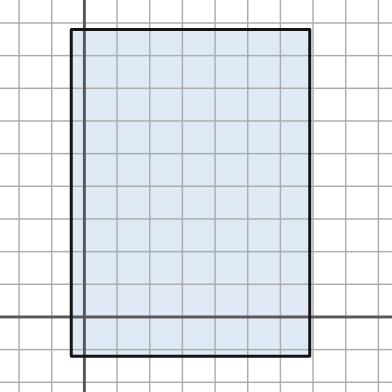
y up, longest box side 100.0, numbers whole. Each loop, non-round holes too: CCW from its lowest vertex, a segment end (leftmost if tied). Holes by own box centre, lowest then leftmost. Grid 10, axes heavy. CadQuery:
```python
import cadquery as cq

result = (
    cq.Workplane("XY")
    .moveTo(-4.0, -12.0)
    .lineTo(69.0, -12.0)
    .lineTo(69.0, 88.0)
    .lineTo(-4.0, 88.0)
    .close()
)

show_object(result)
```